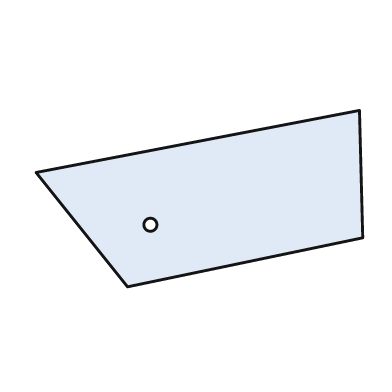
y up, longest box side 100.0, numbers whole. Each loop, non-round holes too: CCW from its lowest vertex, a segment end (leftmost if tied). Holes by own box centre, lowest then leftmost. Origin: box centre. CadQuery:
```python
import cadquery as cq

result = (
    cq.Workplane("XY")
    .moveTo(-22.0, -27.0)
    .lineTo(50.0, -12.0)
    .lineTo(49.0, 27.0)
    .lineTo(-50.0, 8.0)
    .close()
    .moveTo(-15.0, -8.0)
    .circle(2.0)
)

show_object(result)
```